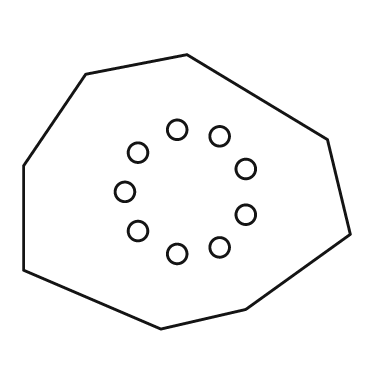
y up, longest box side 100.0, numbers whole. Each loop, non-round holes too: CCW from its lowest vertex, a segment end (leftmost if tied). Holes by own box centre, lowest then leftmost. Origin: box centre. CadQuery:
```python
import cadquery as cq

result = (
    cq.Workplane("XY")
    .moveTo(-8.0, -42.0)
    .lineTo(18.0, -36.0)
    .lineTo(50.0, -13.0)
    .lineTo(43.0, 16.0)
    .lineTo(0.0, 42.0)
    .lineTo(-31.0, 36.0)
    .lineTo(-50.0, 8.0)
    .lineTo(-50.0, -24.0)
    .close()
    .moveTo(-3.0, -19.0)
    .circle(3.0)
    .moveTo(10.0, -17.0)
    .circle(3.0)
    .moveTo(-15.0, -12.0)
    .circle(3.0)
    .moveTo(18.0, -7.0)
    .circle(3.0)
    .moveTo(-19.0, 0.0)
    .circle(3.0)
    .moveTo(18.0, 7.0)
    .circle(3.0)
    .moveTo(-15.0, 12.0)
    .circle(3.0)
    .moveTo(10.0, 17.0)
    .circle(3.0)
    .moveTo(-3.0, 19.0)
    .circle(3.0)
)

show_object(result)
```